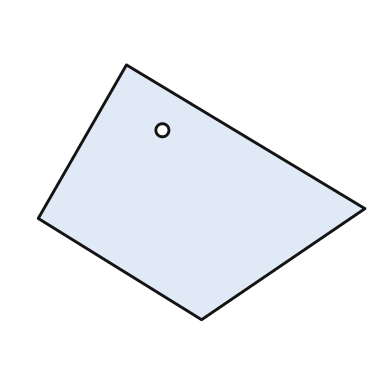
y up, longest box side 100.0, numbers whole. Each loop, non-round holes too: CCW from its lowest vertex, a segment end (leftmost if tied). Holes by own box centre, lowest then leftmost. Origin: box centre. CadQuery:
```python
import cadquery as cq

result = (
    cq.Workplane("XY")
    .moveTo(0.0, -39.0)
    .lineTo(50.0, -5.0)
    .lineTo(-23.0, 39.0)
    .lineTo(-50.0, -8.0)
    .close()
    .moveTo(-12.0, 19.0)
    .circle(2.0)
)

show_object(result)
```